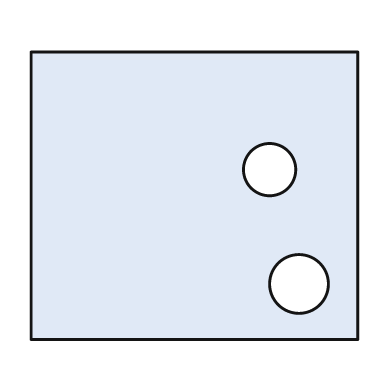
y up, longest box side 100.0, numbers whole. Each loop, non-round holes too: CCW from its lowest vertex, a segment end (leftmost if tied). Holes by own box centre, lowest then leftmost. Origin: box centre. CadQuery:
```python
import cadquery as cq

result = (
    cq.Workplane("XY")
    .moveTo(-50.0, -44.0)
    .lineTo(50.0, -44.0)
    .lineTo(50.0, 44.0)
    .lineTo(-50.0, 44.0)
    .close()
    .moveTo(32.0, -27.0)
    .circle(9.0)
    .moveTo(23.0, 8.0)
    .circle(8.0)
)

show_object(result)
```